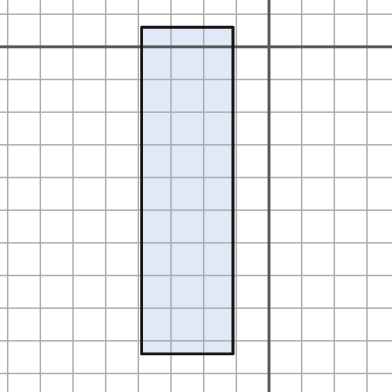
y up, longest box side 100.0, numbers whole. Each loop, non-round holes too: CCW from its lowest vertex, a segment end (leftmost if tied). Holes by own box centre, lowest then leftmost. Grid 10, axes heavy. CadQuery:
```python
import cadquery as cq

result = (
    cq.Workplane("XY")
    .moveTo(-39.0, -94.0)
    .lineTo(-11.0, -94.0)
    .lineTo(-11.0, 6.0)
    .lineTo(-39.0, 6.0)
    .close()
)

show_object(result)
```